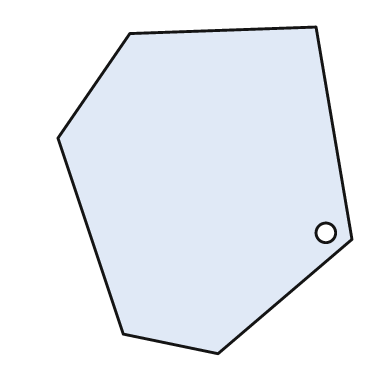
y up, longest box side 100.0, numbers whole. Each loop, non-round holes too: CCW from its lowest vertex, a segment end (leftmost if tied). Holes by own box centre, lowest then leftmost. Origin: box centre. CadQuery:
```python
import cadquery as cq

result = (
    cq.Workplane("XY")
    .moveTo(4.0, -50.0)
    .lineTo(45.0, -15.0)
    .lineTo(34.0, 50.0)
    .lineTo(-23.0, 48.0)
    .lineTo(-45.0, 16.0)
    .lineTo(-25.0, -44.0)
    .close()
    .moveTo(37.0, -13.0)
    .circle(3.0)
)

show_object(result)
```